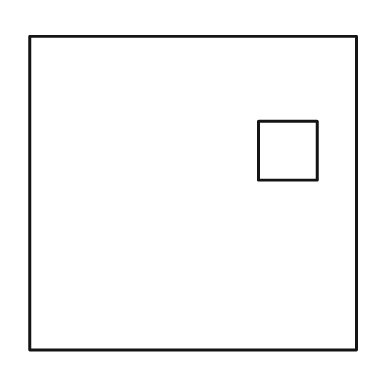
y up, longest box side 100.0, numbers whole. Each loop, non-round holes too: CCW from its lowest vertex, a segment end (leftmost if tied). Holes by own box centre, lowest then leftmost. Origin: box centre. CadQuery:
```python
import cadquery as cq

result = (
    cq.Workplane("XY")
    .moveTo(-50.0, -48.0)
    .lineTo(50.0, -48.0)
    .lineTo(50.0, 48.0)
    .lineTo(-50.0, 48.0)
    .close()
    .moveTo(20.0, 4.0)
    .lineTo(38.0, 4.0)
    .lineTo(38.0, 22.0)
    .lineTo(20.0, 22.0)
    .close()
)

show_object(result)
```